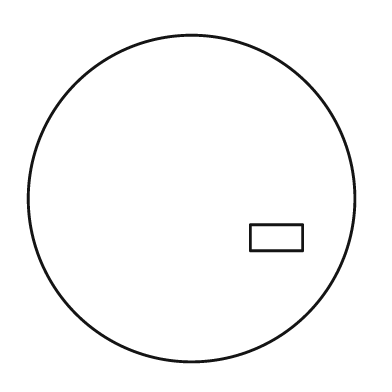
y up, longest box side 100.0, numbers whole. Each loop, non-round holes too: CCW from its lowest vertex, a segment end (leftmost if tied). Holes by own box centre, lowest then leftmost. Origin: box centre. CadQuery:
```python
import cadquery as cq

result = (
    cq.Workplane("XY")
    .moveTo(0.0, 0.0)
    .circle(50.0)
    .moveTo(18.0, -16.0)
    .lineTo(34.0, -16.0)
    .lineTo(34.0, -8.0)
    .lineTo(18.0, -8.0)
    .close()
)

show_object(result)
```